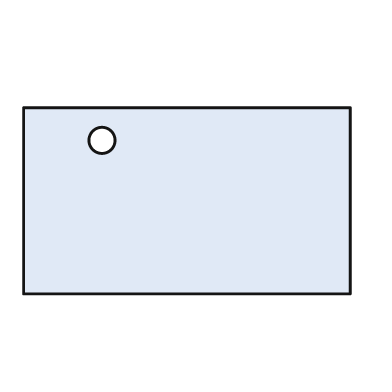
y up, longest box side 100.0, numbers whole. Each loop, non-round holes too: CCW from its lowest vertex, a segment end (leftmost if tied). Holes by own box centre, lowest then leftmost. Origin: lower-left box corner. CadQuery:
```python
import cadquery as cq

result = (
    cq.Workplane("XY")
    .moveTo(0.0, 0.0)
    .lineTo(100.0, 0.0)
    .lineTo(100.0, 57.0)
    .lineTo(0.0, 57.0)
    .close()
    .moveTo(24.0, 47.0)
    .circle(4.0)
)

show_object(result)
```